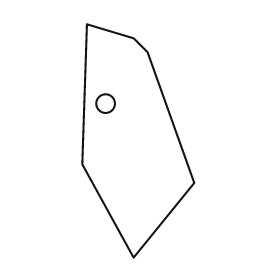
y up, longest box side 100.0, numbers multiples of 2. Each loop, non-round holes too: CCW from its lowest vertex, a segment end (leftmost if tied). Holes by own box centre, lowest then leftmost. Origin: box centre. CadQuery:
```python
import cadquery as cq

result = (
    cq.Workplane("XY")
    .moveTo(-2.0, -50.0)
    .lineTo(24.0, -18.0)
    .lineTo(4.0, 38.0)
    .lineTo(-2.0, 44.0)
    .lineTo(-22.0, 50.0)
    .lineTo(-24.0, -10.0)
    .close()
    .moveTo(-14.0, 16.0)
    .circle(4.0)
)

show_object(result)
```